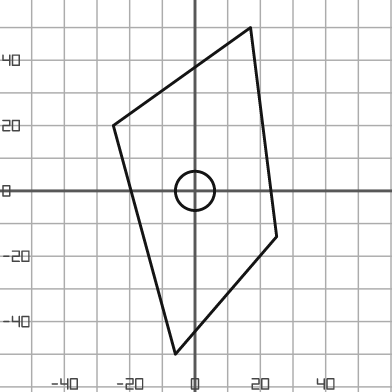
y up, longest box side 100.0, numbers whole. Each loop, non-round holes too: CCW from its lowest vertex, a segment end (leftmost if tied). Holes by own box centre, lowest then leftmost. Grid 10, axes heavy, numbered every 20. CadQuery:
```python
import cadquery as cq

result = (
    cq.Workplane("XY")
    .moveTo(-6.0, -50.0)
    .lineTo(25.0, -14.0)
    .lineTo(17.0, 50.0)
    .lineTo(-25.0, 20.0)
    .close()
    .moveTo(0.0, 0.0)
    .circle(6.0)
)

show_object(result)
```